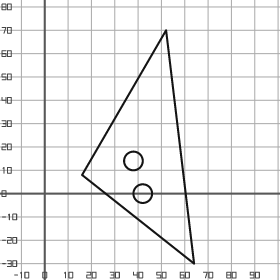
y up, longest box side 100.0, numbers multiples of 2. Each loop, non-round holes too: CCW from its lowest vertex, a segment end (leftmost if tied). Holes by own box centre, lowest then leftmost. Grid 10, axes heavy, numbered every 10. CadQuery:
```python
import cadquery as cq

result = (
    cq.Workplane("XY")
    .moveTo(64.0, -30.0)
    .lineTo(52.0, 70.0)
    .lineTo(16.0, 8.0)
    .close()
    .moveTo(42.0, 0.0)
    .circle(4.0)
    .moveTo(38.0, 14.0)
    .circle(4.0)
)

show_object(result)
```